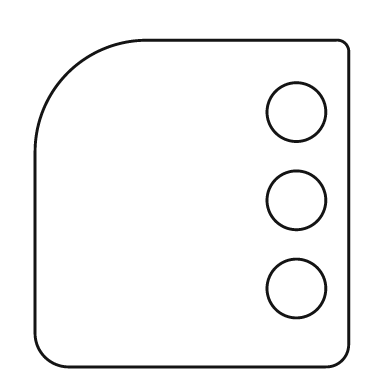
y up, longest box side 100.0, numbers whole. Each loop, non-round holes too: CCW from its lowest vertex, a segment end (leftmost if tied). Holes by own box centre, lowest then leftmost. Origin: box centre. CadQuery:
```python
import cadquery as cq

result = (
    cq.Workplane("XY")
    .moveTo(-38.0, -50.0)
    .lineTo(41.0, -50.0)
    .threePointArc((46.0, -48.0), (48.0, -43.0))
    .lineTo(48.0, 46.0)
    .threePointArc((47.0, 49.0), (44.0, 50.0))
    .lineTo(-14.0, 50.0)
    .threePointArc((-38.0, 40.0), (-48.0, 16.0))
    .lineTo(-48.0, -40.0)
    .threePointArc((-45.0, -47.0), (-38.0, -50.0))
    .close()
    .moveTo(32.0, -26.0)
    .circle(9.0)
    .moveTo(32.0, 1.0)
    .circle(9.0)
    .moveTo(32.0, 28.0)
    .circle(9.0)
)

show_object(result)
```